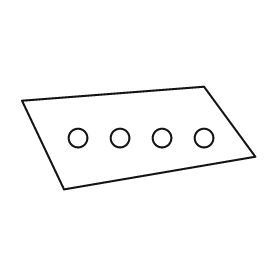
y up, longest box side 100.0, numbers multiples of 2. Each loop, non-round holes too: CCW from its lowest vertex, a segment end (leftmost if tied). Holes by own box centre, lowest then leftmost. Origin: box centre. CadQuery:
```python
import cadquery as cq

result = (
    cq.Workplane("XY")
    .moveTo(-32.0, -22.0)
    .lineTo(50.0, -8.0)
    .lineTo(28.0, 22.0)
    .lineTo(-50.0, 16.0)
    .close()
    .moveTo(-26.0, 0.0)
    .circle(4.0)
    .moveTo(-8.0, 0.0)
    .circle(4.0)
    .moveTo(10.0, 0.0)
    .circle(4.0)
    .moveTo(28.0, 0.0)
    .circle(4.0)
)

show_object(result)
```